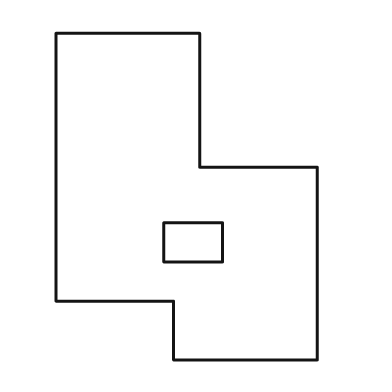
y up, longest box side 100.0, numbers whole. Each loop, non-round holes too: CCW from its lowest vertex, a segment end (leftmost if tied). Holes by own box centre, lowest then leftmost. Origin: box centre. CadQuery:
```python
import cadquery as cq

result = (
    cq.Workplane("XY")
    .moveTo(-4.0, -50.0)
    .lineTo(40.0, -50.0)
    .lineTo(40.0, 9.0)
    .lineTo(4.0, 9.0)
    .lineTo(4.0, 50.0)
    .lineTo(-40.0, 50.0)
    .lineTo(-40.0, -32.0)
    .lineTo(-4.0, -32.0)
    .close()
    .moveTo(-7.0, -20.0)
    .lineTo(11.0, -20.0)
    .lineTo(11.0, -8.0)
    .lineTo(-7.0, -8.0)
    .close()
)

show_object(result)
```